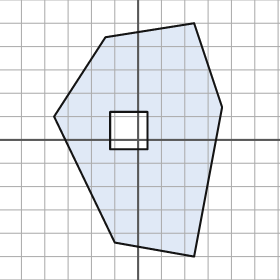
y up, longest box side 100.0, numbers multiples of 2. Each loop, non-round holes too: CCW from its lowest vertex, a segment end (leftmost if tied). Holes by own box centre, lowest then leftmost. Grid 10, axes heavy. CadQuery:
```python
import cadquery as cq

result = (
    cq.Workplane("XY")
    .moveTo(24.0, -50.0)
    .lineTo(36.0, 14.0)
    .lineTo(24.0, 50.0)
    .lineTo(-14.0, 44.0)
    .lineTo(-36.0, 10.0)
    .lineTo(-10.0, -44.0)
    .close()
    .moveTo(-12.0, -4.0)
    .lineTo(4.0, -4.0)
    .lineTo(4.0, 12.0)
    .lineTo(-12.0, 12.0)
    .close()
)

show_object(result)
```